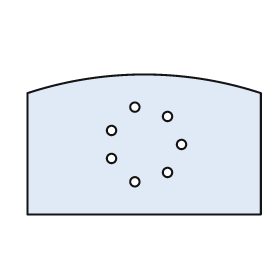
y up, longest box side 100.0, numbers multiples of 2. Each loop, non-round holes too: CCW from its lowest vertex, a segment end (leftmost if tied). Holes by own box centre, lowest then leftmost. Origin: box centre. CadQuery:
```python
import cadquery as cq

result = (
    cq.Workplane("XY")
    .moveTo(-50.0, -30.0)
    .lineTo(50.0, -30.0)
    .lineTo(50.0, 22.0)
    .threePointArc((0.0, 30.0), (-50.0, 22.0))
    .close()
    .moveTo(-4.0, -16.0)
    .circle(2.0)
    .moveTo(10.0, -12.0)
    .circle(2.0)
    .moveTo(-14.0, -6.0)
    .circle(2.0)
    .moveTo(16.0, 0.0)
    .circle(2.0)
    .moveTo(-14.0, 6.0)
    .circle(2.0)
    .moveTo(10.0, 12.0)
    .circle(2.0)
    .moveTo(-4.0, 16.0)
    .circle(2.0)
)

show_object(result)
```